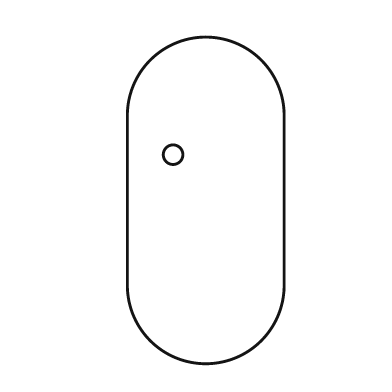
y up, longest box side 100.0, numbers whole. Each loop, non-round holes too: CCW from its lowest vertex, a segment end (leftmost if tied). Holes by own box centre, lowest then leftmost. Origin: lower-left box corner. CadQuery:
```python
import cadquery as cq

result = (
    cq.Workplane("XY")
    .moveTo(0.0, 24.0)
    .threePointArc((24.0, 0.0), (48.0, 24.0))
    .lineTo(48.0, 76.0)
    .threePointArc((24.0, 100.0), (0.0, 76.0))
    .close()
    .moveTo(14.0, 64.0)
    .circle(3.0)
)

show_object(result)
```